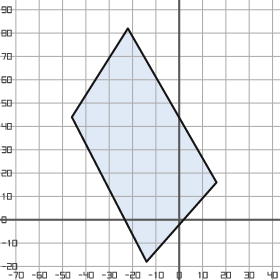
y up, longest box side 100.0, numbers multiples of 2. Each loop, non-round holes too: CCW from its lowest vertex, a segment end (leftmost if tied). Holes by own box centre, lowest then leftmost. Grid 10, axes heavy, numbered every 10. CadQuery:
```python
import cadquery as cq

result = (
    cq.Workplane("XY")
    .moveTo(-14.0, -18.0)
    .lineTo(16.0, 16.0)
    .lineTo(-22.0, 82.0)
    .lineTo(-46.0, 44.0)
    .close()
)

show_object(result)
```